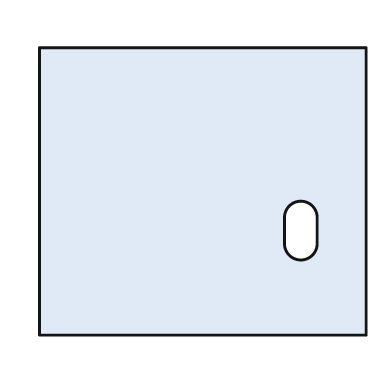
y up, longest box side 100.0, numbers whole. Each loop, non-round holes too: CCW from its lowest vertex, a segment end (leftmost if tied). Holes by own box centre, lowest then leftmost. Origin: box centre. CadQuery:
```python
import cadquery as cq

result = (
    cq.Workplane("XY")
    .moveTo(-50.0, -44.0)
    .lineTo(50.0, -44.0)
    .lineTo(50.0, 44.0)
    .lineTo(-50.0, 44.0)
    .close()
    .moveTo(25.0, -16.0)
    .threePointArc((30.0, -21.0), (35.0, -16.0))
    .lineTo(35.0, -8.0)
    .threePointArc((30.0, -3.0), (25.0, -8.0))
    .close()
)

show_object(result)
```